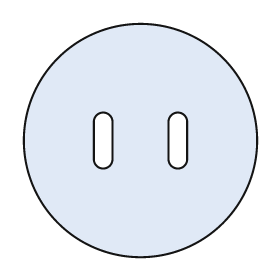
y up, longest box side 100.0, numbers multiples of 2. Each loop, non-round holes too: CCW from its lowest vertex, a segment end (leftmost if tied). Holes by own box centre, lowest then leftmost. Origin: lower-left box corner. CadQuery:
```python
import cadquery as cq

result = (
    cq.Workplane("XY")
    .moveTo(50.0, 50.0)
    .circle(50.0)
    .moveTo(30.0, 42.0)
    .threePointArc((34.0, 38.0), (38.0, 42.0))
    .lineTo(38.0, 58.0)
    .threePointArc((34.0, 62.0), (30.0, 58.0))
    .close()
    .moveTo(62.0, 42.0)
    .threePointArc((66.0, 38.0), (70.0, 42.0))
    .lineTo(70.0, 58.0)
    .threePointArc((66.0, 62.0), (62.0, 58.0))
    .close()
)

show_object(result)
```